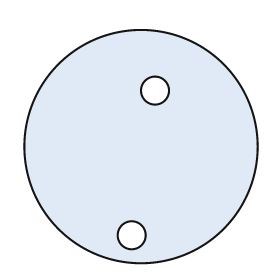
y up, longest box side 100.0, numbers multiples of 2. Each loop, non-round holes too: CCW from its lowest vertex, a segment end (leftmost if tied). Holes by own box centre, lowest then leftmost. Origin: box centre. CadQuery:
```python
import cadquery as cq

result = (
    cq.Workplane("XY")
    .moveTo(0.0, 0.0)
    .circle(50.0)
    .moveTo(-4.0, -38.0)
    .circle(6.0)
    .moveTo(6.0, 24.0)
    .circle(6.0)
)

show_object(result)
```